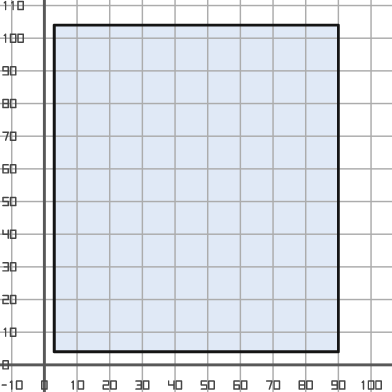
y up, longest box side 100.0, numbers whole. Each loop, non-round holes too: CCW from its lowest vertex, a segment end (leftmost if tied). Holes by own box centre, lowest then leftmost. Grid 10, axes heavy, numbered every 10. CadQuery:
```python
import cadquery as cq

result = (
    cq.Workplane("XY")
    .moveTo(3.0, 4.0)
    .lineTo(90.0, 4.0)
    .lineTo(90.0, 104.0)
    .lineTo(3.0, 104.0)
    .close()
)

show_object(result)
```